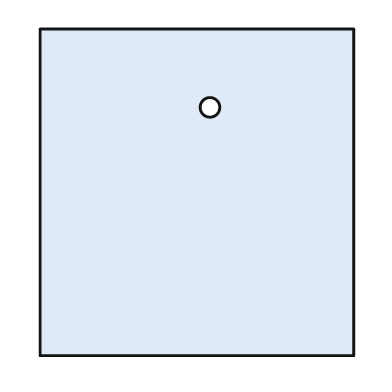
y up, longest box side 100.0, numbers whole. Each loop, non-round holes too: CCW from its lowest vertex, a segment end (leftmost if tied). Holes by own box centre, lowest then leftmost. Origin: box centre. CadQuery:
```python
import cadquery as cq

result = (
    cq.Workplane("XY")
    .moveTo(-48.0, -50.0)
    .lineTo(48.0, -50.0)
    .lineTo(48.0, 50.0)
    .lineTo(-48.0, 50.0)
    .close()
    .moveTo(4.0, 26.0)
    .circle(3.0)
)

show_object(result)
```